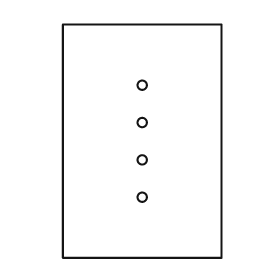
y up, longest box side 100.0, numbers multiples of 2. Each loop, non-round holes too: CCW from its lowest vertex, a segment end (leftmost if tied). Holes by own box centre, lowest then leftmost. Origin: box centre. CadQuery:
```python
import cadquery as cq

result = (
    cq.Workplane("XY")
    .moveTo(-34.0, -50.0)
    .lineTo(34.0, -50.0)
    .lineTo(34.0, 50.0)
    .lineTo(-34.0, 50.0)
    .close()
    .moveTo(0.0, -24.0)
    .circle(2.0)
    .moveTo(0.0, -8.0)
    .circle(2.0)
    .moveTo(0.0, 8.0)
    .circle(2.0)
    .moveTo(0.0, 24.0)
    .circle(2.0)
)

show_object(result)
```